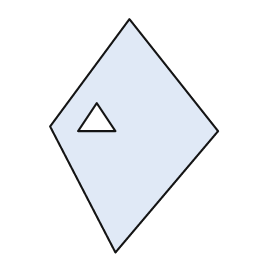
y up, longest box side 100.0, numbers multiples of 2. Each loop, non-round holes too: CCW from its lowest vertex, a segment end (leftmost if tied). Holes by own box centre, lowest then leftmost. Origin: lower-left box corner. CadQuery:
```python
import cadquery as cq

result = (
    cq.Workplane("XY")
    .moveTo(28.0, 0.0)
    .lineTo(72.0, 52.0)
    .lineTo(34.0, 100.0)
    .lineTo(0.0, 54.0)
    .close()
    .moveTo(12.0, 52.0)
    .lineTo(28.0, 52.0)
    .lineTo(20.0, 64.0)
    .close()
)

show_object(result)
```